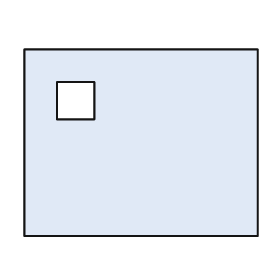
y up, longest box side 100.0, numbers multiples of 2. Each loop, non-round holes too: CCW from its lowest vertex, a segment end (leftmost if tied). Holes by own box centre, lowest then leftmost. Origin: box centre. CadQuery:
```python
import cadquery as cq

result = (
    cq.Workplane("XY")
    .moveTo(-50.0, -40.0)
    .lineTo(50.0, -40.0)
    .lineTo(50.0, 40.0)
    .lineTo(-50.0, 40.0)
    .close()
    .moveTo(-36.0, 10.0)
    .lineTo(-20.0, 10.0)
    .lineTo(-20.0, 26.0)
    .lineTo(-36.0, 26.0)
    .close()
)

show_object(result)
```